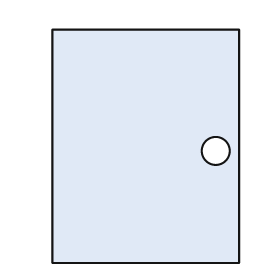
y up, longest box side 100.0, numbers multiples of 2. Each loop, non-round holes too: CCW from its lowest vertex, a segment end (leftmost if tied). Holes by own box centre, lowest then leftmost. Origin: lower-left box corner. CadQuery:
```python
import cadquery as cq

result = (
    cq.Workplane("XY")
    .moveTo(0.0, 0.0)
    .lineTo(80.0, 0.0)
    .lineTo(80.0, 100.0)
    .lineTo(0.0, 100.0)
    .close()
    .moveTo(70.0, 48.0)
    .circle(6.0)
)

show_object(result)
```